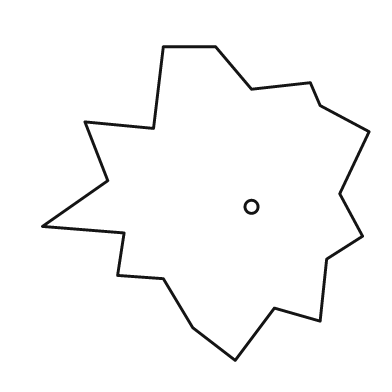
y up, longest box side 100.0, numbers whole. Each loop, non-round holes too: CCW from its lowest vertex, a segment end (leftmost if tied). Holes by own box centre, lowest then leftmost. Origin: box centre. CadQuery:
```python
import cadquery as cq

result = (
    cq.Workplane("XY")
    .moveTo(9.0, -48.0)
    .lineTo(21.0, -32.0)
    .lineTo(35.0, -36.0)
    .lineTo(37.0, -17.0)
    .lineTo(48.0, -10.0)
    .lineTo(41.0, 3.0)
    .lineTo(50.0, 22.0)
    .lineTo(35.0, 30.0)
    .lineTo(32.0, 37.0)
    .lineTo(14.0, 35.0)
    .lineTo(3.0, 48.0)
    .lineTo(-13.0, 48.0)
    .lineTo(-16.0, 23.0)
    .lineTo(-37.0, 25.0)
    .lineTo(-30.0, 7.0)
    .lineTo(-50.0, -7.0)
    .lineTo(-25.0, -9.0)
    .lineTo(-27.0, -22.0)
    .lineTo(-13.0, -23.0)
    .lineTo(-4.0, -38.0)
    .close()
    .moveTo(14.0, -1.0)
    .circle(2.0)
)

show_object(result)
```